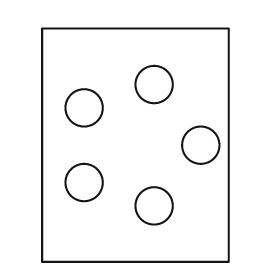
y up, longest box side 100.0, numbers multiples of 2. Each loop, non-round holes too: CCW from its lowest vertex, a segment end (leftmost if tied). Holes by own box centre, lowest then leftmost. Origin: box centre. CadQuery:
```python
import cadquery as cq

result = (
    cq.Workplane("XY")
    .moveTo(-40.0, -50.0)
    .lineTo(40.0, -50.0)
    .lineTo(40.0, 50.0)
    .lineTo(-40.0, 50.0)
    .close()
    .moveTo(8.0, -26.0)
    .circle(8.0)
    .moveTo(-22.0, -16.0)
    .circle(8.0)
    .moveTo(28.0, 0.0)
    .circle(8.0)
    .moveTo(-22.0, 16.0)
    .circle(8.0)
    .moveTo(8.0, 26.0)
    .circle(8.0)
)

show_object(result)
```